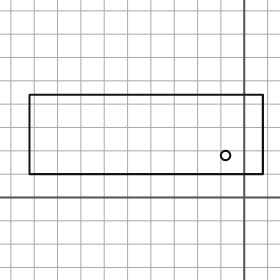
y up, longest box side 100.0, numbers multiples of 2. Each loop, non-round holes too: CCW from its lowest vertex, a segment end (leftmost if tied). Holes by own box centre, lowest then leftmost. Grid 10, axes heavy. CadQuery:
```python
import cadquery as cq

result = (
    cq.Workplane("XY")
    .moveTo(-92.0, 10.0)
    .lineTo(8.0, 10.0)
    .lineTo(8.0, 44.0)
    .lineTo(-92.0, 44.0)
    .close()
    .moveTo(-8.0, 18.0)
    .circle(2.0)
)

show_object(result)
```